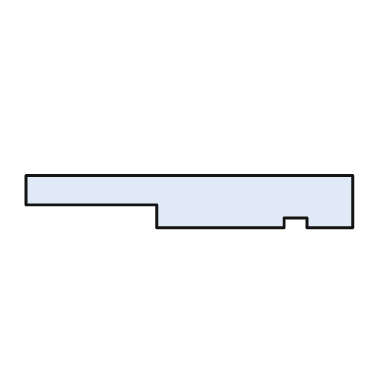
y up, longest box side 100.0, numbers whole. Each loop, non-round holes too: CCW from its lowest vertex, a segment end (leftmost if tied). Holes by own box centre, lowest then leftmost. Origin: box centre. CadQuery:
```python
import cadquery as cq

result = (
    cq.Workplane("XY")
    .moveTo(-10.0, -8.0)
    .lineTo(29.0, -8.0)
    .lineTo(29.0, -5.0)
    .lineTo(36.0, -5.0)
    .lineTo(36.0, -8.0)
    .lineTo(50.0, -8.0)
    .lineTo(50.0, 8.0)
    .lineTo(-50.0, 8.0)
    .lineTo(-50.0, -1.0)
    .lineTo(-10.0, -1.0)
    .close()
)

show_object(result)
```